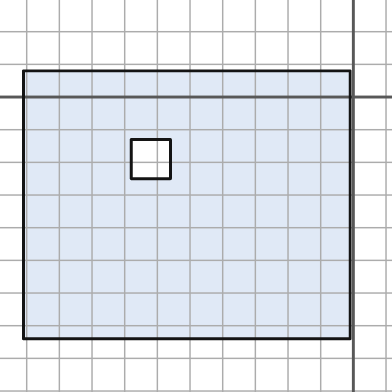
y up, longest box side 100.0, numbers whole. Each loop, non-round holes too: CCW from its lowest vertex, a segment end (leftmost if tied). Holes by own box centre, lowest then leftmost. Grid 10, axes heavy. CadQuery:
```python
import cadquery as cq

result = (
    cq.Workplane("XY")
    .moveTo(-101.0, -74.0)
    .lineTo(-1.0, -74.0)
    .lineTo(-1.0, 8.0)
    .lineTo(-101.0, 8.0)
    .close()
    .moveTo(-68.0, -25.0)
    .lineTo(-56.0, -25.0)
    .lineTo(-56.0, -13.0)
    .lineTo(-68.0, -13.0)
    .close()
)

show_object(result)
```